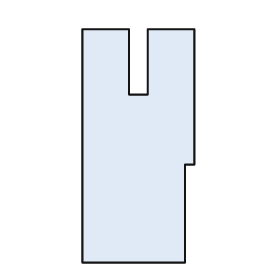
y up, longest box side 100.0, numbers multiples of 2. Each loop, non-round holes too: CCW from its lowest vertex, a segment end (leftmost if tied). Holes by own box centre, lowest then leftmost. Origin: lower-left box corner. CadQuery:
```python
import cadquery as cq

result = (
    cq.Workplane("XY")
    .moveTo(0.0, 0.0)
    .lineTo(44.0, 0.0)
    .lineTo(44.0, 42.0)
    .lineTo(48.0, 42.0)
    .lineTo(48.0, 100.0)
    .lineTo(28.0, 100.0)
    .lineTo(28.0, 72.0)
    .lineTo(20.0, 72.0)
    .lineTo(20.0, 100.0)
    .lineTo(0.0, 100.0)
    .close()
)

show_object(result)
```